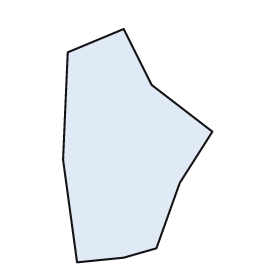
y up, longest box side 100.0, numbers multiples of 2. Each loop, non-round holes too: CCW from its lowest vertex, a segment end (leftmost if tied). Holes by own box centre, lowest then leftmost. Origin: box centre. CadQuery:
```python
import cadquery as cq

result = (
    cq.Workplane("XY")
    .moveTo(-26.0, -50.0)
    .lineTo(-6.0, -48.0)
    .lineTo(8.0, -44.0)
    .lineTo(18.0, -16.0)
    .lineTo(32.0, 6.0)
    .lineTo(6.0, 26.0)
    .lineTo(-6.0, 50.0)
    .lineTo(-30.0, 40.0)
    .lineTo(-32.0, -6.0)
    .close()
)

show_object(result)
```